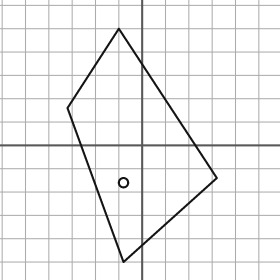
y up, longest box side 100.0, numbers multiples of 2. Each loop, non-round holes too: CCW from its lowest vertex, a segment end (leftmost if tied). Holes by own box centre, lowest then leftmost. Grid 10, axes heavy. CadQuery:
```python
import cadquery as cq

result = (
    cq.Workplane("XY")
    .moveTo(-8.0, -50.0)
    .lineTo(32.0, -14.0)
    .lineTo(-10.0, 50.0)
    .lineTo(-32.0, 16.0)
    .close()
    .moveTo(-8.0, -16.0)
    .circle(2.0)
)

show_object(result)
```